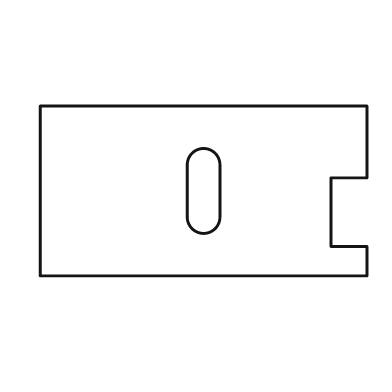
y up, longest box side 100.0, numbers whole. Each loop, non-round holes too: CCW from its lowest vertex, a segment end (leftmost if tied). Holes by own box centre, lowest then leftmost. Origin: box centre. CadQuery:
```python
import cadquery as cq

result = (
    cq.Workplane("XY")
    .moveTo(-50.0, -26.0)
    .lineTo(50.0, -26.0)
    .lineTo(50.0, -17.0)
    .lineTo(39.0, -17.0)
    .lineTo(39.0, 4.0)
    .lineTo(50.0, 4.0)
    .lineTo(50.0, 26.0)
    .lineTo(-50.0, 26.0)
    .close()
    .moveTo(-5.0, -8.0)
    .threePointArc((0.0, -13.0), (5.0, -8.0))
    .lineTo(5.0, 8.0)
    .threePointArc((0.0, 13.0), (-5.0, 8.0))
    .close()
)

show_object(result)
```